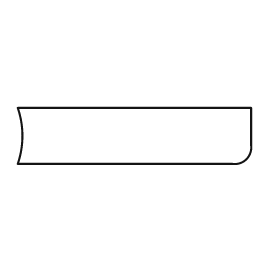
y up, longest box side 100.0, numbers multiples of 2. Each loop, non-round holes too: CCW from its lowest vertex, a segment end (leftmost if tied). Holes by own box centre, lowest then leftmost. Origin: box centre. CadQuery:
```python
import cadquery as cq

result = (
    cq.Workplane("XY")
    .moveTo(-50.0, -12.0)
    .lineTo(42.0, -12.0)
    .threePointArc((48.0, -10.0), (50.0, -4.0))
    .lineTo(50.0, 12.0)
    .lineTo(-50.0, 12.0)
    .threePointArc((-48.0, 0.0), (-50.0, -12.0))
    .close()
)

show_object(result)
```